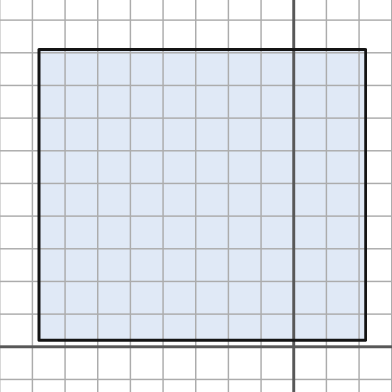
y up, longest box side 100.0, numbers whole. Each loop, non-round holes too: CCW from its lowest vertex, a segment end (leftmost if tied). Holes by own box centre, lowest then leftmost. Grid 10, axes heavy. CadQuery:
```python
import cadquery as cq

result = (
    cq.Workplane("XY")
    .moveTo(-78.0, 2.0)
    .lineTo(22.0, 2.0)
    .lineTo(22.0, 91.0)
    .lineTo(-78.0, 91.0)
    .close()
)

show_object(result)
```